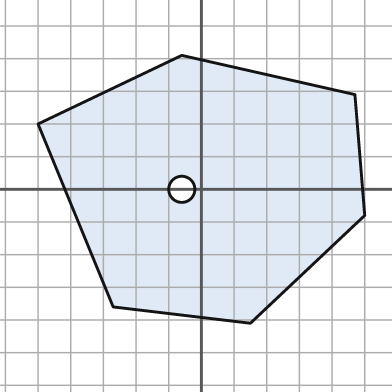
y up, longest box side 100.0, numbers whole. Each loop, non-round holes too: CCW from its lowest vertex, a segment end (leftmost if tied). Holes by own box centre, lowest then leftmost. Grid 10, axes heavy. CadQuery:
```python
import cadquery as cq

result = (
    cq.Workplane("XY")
    .moveTo(15.0, -41.0)
    .lineTo(50.0, -8.0)
    .lineTo(47.0, 29.0)
    .lineTo(-6.0, 41.0)
    .lineTo(-50.0, 20.0)
    .lineTo(-27.0, -36.0)
    .close()
    .moveTo(-6.0, 0.0)
    .circle(4.0)
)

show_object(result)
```